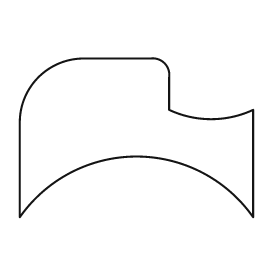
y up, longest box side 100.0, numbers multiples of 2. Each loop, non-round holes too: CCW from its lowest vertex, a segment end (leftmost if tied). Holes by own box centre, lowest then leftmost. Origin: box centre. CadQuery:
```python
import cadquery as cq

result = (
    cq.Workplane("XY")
    .moveTo(-50.0, -34.0)
    .threePointArc((0.0, -8.0), (50.0, -34.0))
    .lineTo(50.0, 12.0)
    .threePointArc((32.0, 8.0), (14.0, 12.0))
    .lineTo(14.0, 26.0)
    .threePointArc((12.0, 32.0), (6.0, 34.0))
    .lineTo(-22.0, 34.0)
    .threePointArc((-42.0, 26.0), (-50.0, 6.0))
    .close()
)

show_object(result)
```